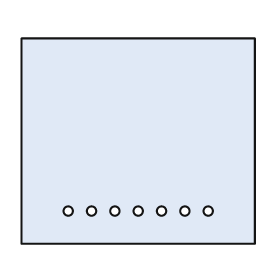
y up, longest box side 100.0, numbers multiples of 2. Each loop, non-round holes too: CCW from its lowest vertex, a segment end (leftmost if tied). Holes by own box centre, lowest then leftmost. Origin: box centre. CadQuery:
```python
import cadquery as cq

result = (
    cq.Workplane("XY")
    .moveTo(-50.0, -44.0)
    .lineTo(50.0, -44.0)
    .lineTo(50.0, 44.0)
    .lineTo(-50.0, 44.0)
    .close()
    .moveTo(-30.0, -30.0)
    .circle(2.0)
    .moveTo(-20.0, -30.0)
    .circle(2.0)
    .moveTo(-10.0, -30.0)
    .circle(2.0)
    .moveTo(0.0, -30.0)
    .circle(2.0)
    .moveTo(10.0, -30.0)
    .circle(2.0)
    .moveTo(20.0, -30.0)
    .circle(2.0)
    .moveTo(30.0, -30.0)
    .circle(2.0)
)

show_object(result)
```